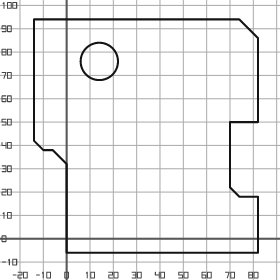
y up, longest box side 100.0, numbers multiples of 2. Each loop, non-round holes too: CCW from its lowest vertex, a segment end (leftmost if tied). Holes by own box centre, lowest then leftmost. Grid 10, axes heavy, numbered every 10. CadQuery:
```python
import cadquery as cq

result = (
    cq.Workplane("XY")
    .moveTo(0.0, -6.0)
    .lineTo(82.0, -6.0)
    .lineTo(82.0, 18.0)
    .lineTo(74.0, 18.0)
    .lineTo(70.0, 22.0)
    .lineTo(70.0, 50.0)
    .lineTo(82.0, 50.0)
    .lineTo(82.0, 86.0)
    .lineTo(74.0, 94.0)
    .lineTo(-14.0, 94.0)
    .lineTo(-14.0, 42.0)
    .lineTo(-10.0, 38.0)
    .lineTo(-6.0, 38.0)
    .lineTo(0.0, 32.0)
    .close()
    .moveTo(14.0, 76.0)
    .circle(8.0)
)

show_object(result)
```